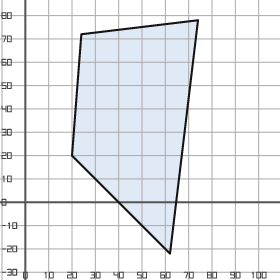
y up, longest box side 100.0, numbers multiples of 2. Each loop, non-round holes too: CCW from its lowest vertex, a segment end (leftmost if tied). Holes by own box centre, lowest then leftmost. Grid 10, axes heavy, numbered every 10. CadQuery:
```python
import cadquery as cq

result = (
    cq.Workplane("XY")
    .moveTo(62.0, -22.0)
    .lineTo(74.0, 78.0)
    .lineTo(24.0, 72.0)
    .lineTo(20.0, 20.0)
    .close()
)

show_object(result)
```